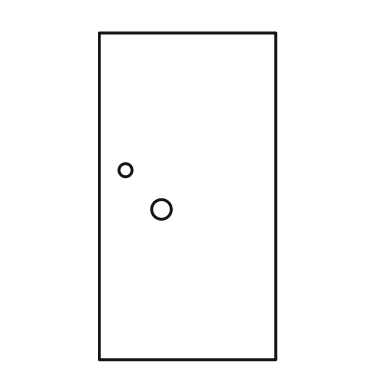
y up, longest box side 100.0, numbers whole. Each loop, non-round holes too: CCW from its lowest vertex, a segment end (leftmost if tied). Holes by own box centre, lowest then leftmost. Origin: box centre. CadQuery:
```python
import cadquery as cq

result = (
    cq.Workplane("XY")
    .moveTo(-27.0, -50.0)
    .lineTo(27.0, -50.0)
    .lineTo(27.0, 50.0)
    .lineTo(-27.0, 50.0)
    .close()
    .moveTo(-8.0, -4.0)
    .circle(3.0)
    .moveTo(-19.0, 8.0)
    .circle(2.0)
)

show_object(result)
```